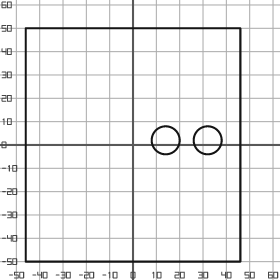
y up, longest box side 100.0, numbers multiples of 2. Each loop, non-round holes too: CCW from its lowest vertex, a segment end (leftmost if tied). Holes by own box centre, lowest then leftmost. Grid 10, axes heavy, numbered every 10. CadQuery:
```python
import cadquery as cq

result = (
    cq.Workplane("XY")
    .moveTo(-46.0, -50.0)
    .lineTo(46.0, -50.0)
    .lineTo(46.0, 50.0)
    .lineTo(-46.0, 50.0)
    .close()
    .moveTo(14.0, 2.0)
    .circle(6.0)
    .moveTo(32.0, 2.0)
    .circle(6.0)
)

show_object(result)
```